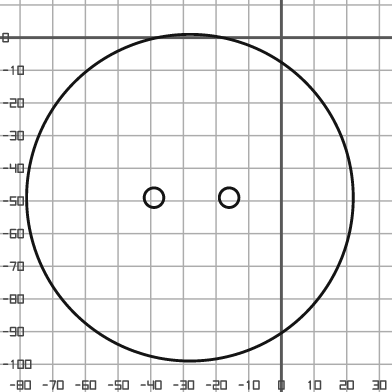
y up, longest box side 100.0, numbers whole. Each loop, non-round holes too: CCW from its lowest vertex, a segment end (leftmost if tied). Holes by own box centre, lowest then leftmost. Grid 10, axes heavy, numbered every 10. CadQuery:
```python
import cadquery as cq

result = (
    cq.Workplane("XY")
    .moveTo(-28.0, -49.0)
    .circle(50.0)
    .moveTo(-39.0, -49.0)
    .circle(3.0)
    .moveTo(-16.0, -49.0)
    .circle(3.0)
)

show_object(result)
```